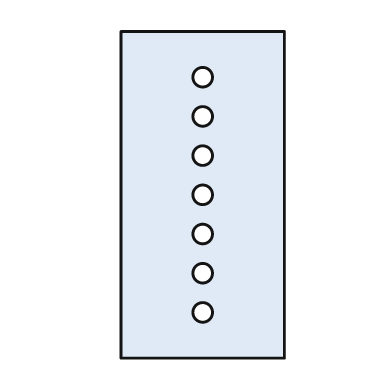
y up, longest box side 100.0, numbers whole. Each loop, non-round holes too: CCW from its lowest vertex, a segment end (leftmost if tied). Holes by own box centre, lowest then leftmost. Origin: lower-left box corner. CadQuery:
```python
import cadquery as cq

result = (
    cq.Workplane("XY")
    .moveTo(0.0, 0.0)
    .lineTo(50.0, 0.0)
    .lineTo(50.0, 100.0)
    .lineTo(0.0, 100.0)
    .close()
    .moveTo(25.0, 14.0)
    .circle(3.0)
    .moveTo(25.0, 26.0)
    .circle(3.0)
    .moveTo(25.0, 38.0)
    .circle(3.0)
    .moveTo(25.0, 50.0)
    .circle(3.0)
    .moveTo(25.0, 62.0)
    .circle(3.0)
    .moveTo(25.0, 74.0)
    .circle(3.0)
    .moveTo(25.0, 86.0)
    .circle(3.0)
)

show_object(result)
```